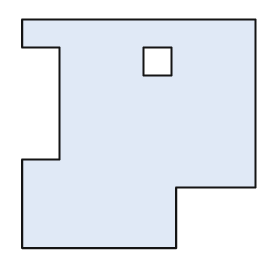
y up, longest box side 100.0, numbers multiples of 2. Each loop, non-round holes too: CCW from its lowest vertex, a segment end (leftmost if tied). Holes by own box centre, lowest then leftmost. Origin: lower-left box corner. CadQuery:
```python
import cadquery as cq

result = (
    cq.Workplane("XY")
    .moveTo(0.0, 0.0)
    .lineTo(66.0, 0.0)
    .lineTo(66.0, 26.0)
    .lineTo(100.0, 26.0)
    .lineTo(100.0, 98.0)
    .lineTo(0.0, 98.0)
    .lineTo(0.0, 86.0)
    .lineTo(16.0, 86.0)
    .lineTo(16.0, 38.0)
    .lineTo(0.0, 38.0)
    .close()
    .moveTo(52.0, 74.0)
    .lineTo(64.0, 74.0)
    .lineTo(64.0, 86.0)
    .lineTo(52.0, 86.0)
    .close()
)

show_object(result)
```